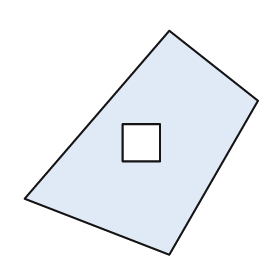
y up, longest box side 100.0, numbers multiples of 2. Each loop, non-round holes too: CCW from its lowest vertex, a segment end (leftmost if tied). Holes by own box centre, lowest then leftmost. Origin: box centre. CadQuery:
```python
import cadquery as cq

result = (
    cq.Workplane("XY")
    .moveTo(12.0, -48.0)
    .lineTo(50.0, 18.0)
    .lineTo(12.0, 48.0)
    .lineTo(-50.0, -24.0)
    .close()
    .moveTo(-8.0, -8.0)
    .lineTo(8.0, -8.0)
    .lineTo(8.0, 8.0)
    .lineTo(-8.0, 8.0)
    .close()
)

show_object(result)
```